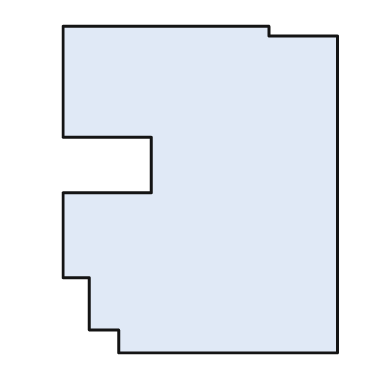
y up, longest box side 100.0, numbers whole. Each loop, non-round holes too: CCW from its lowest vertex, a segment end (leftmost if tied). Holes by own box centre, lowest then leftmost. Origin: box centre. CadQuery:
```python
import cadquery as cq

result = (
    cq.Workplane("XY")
    .moveTo(-25.0, -50.0)
    .lineTo(42.0, -50.0)
    .lineTo(42.0, 47.0)
    .lineTo(21.0, 47.0)
    .lineTo(21.0, 50.0)
    .lineTo(-42.0, 50.0)
    .lineTo(-42.0, 16.0)
    .lineTo(-15.0, 16.0)
    .lineTo(-15.0, -1.0)
    .lineTo(-42.0, -1.0)
    .lineTo(-42.0, -27.0)
    .lineTo(-34.0, -27.0)
    .lineTo(-34.0, -43.0)
    .lineTo(-25.0, -43.0)
    .close()
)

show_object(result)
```